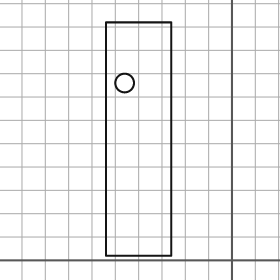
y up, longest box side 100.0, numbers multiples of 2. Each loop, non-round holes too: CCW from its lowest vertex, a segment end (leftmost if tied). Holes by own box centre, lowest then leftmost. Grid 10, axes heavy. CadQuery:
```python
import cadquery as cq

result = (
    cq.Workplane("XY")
    .moveTo(-54.0, 2.0)
    .lineTo(-26.0, 2.0)
    .lineTo(-26.0, 102.0)
    .lineTo(-54.0, 102.0)
    .close()
    .moveTo(-46.0, 76.0)
    .circle(4.0)
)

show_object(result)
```